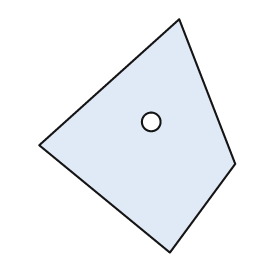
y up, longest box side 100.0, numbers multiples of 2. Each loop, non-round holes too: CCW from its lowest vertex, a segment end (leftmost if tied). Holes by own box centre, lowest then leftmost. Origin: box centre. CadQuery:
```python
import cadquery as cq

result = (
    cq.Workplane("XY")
    .moveTo(14.0, -50.0)
    .lineTo(42.0, -12.0)
    .lineTo(18.0, 50.0)
    .lineTo(-42.0, -4.0)
    .close()
    .moveTo(6.0, 6.0)
    .circle(4.0)
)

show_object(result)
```